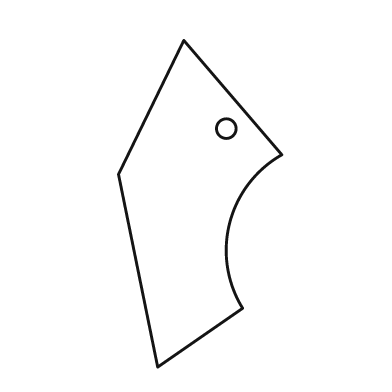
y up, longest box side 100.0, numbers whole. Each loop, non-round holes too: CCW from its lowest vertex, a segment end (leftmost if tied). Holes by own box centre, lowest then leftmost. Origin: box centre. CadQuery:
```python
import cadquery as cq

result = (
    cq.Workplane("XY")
    .moveTo(-13.0, -50.0)
    .lineTo(13.0, -32.0)
    .threePointArc((9.0, -6.0), (25.0, 15.0))
    .lineTo(-5.0, 50.0)
    .lineTo(-25.0, 9.0)
    .close()
    .moveTo(8.0, 23.0)
    .circle(3.0)
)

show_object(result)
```